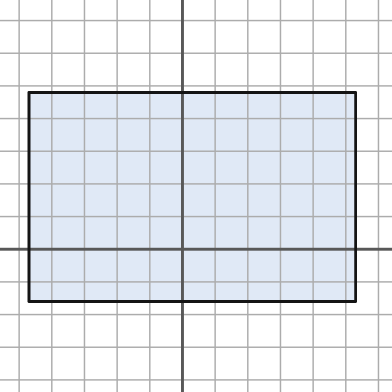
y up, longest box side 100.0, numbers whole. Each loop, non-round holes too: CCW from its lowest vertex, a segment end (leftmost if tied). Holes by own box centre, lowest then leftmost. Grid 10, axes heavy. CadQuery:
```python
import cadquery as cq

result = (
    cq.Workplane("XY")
    .moveTo(-47.0, -16.0)
    .lineTo(53.0, -16.0)
    .lineTo(53.0, 48.0)
    .lineTo(-47.0, 48.0)
    .close()
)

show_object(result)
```